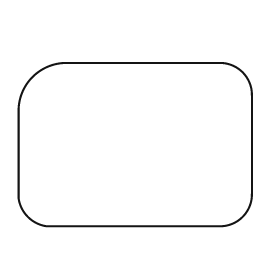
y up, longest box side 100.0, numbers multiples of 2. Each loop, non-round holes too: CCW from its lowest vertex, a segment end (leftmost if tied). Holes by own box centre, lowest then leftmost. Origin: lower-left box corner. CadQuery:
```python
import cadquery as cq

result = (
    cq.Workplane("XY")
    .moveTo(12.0, 0.0)
    .lineTo(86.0, 0.0)
    .threePointArc((96.0, 4.0), (100.0, 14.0))
    .lineTo(100.0, 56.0)
    .threePointArc((96.0, 66.0), (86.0, 70.0))
    .lineTo(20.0, 70.0)
    .threePointArc((6.0, 64.0), (0.0, 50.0))
    .lineTo(0.0, 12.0)
    .threePointArc((4.0, 4.0), (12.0, 0.0))
    .close()
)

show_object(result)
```